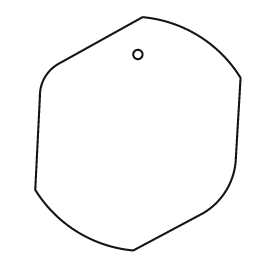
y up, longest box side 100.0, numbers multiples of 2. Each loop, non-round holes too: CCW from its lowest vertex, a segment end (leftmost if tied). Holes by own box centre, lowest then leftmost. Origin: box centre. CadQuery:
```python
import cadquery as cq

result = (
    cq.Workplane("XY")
    .moveTo(-2.0, -50.0)
    .lineTo(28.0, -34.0)
    .threePointArc((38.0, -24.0), (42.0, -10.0))
    .lineTo(44.0, 24.0)
    .threePointArc((26.0, 42.0), (2.0, 50.0))
    .lineTo(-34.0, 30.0)
    .threePointArc((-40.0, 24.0), (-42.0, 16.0))
    .lineTo(-44.0, -24.0)
    .threePointArc((-26.0, -42.0), (-2.0, -50.0))
    .close()
    .moveTo(0.0, 34.0)
    .circle(2.0)
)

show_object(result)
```